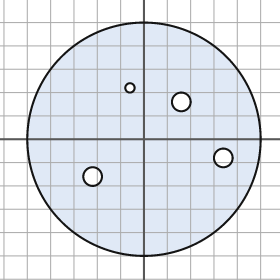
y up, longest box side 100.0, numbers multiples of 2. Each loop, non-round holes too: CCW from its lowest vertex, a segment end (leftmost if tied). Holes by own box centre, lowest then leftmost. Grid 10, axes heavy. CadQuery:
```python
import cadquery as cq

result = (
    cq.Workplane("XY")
    .moveTo(0.0, 0.0)
    .circle(50.0)
    .moveTo(-22.0, -16.0)
    .circle(4.0)
    .moveTo(34.0, -8.0)
    .circle(4.0)
    .moveTo(16.0, 16.0)
    .circle(4.0)
    .moveTo(-6.0, 22.0)
    .circle(2.0)
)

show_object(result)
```